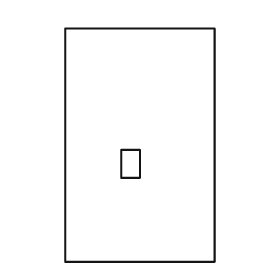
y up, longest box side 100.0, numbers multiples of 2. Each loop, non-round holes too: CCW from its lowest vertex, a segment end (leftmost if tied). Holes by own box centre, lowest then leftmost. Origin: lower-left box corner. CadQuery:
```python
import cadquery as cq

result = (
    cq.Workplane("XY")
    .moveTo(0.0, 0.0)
    .lineTo(64.0, 0.0)
    .lineTo(64.0, 100.0)
    .lineTo(0.0, 100.0)
    .close()
    .moveTo(24.0, 36.0)
    .lineTo(32.0, 36.0)
    .lineTo(32.0, 48.0)
    .lineTo(24.0, 48.0)
    .close()
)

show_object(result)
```